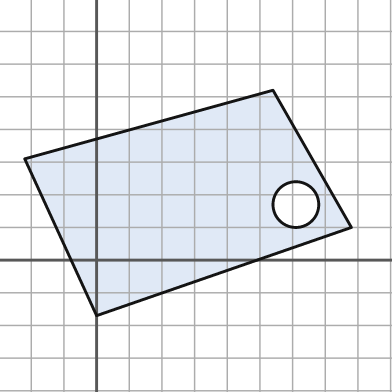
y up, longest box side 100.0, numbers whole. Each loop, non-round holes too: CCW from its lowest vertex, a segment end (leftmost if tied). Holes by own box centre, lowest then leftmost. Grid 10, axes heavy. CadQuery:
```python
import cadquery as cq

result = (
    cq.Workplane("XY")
    .moveTo(0.0, -17.0)
    .lineTo(78.0, 10.0)
    .lineTo(54.0, 52.0)
    .lineTo(-22.0, 31.0)
    .close()
    .moveTo(61.0, 17.0)
    .circle(7.0)
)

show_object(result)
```